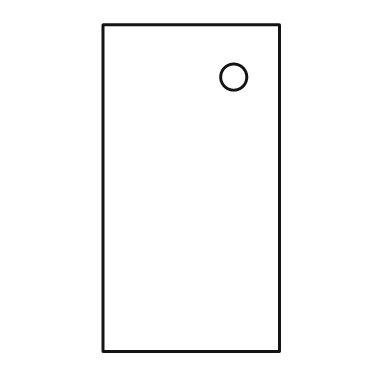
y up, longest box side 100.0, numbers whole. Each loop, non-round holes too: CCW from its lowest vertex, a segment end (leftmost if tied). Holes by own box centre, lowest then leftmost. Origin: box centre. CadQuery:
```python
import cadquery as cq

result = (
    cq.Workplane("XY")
    .moveTo(-27.0, -50.0)
    .lineTo(27.0, -50.0)
    .lineTo(27.0, 50.0)
    .lineTo(-27.0, 50.0)
    .close()
    .moveTo(13.0, 34.0)
    .circle(4.0)
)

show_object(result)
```